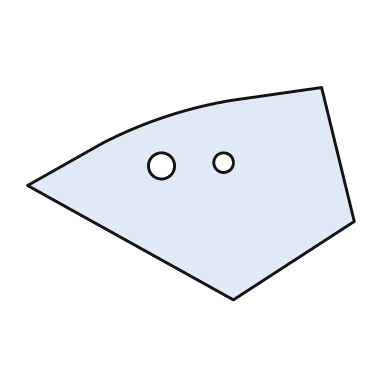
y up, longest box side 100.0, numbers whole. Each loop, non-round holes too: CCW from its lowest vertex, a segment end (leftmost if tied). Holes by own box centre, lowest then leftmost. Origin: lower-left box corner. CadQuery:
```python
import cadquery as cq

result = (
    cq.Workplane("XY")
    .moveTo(63.0, 0.0)
    .lineTo(100.0, 24.0)
    .lineTo(90.0, 65.0)
    .lineTo(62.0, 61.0)
    .threePointArc((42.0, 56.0), (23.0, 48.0))
    .lineTo(0.0, 35.0)
    .close()
    .moveTo(41.0, 41.0)
    .circle(4.0)
    .moveTo(60.0, 42.0)
    .circle(3.0)
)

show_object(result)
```